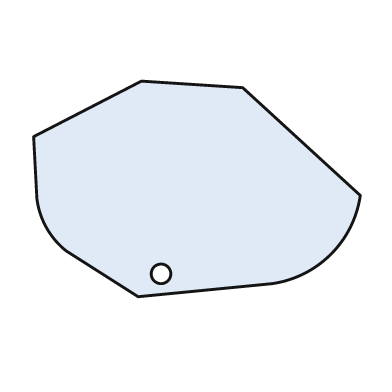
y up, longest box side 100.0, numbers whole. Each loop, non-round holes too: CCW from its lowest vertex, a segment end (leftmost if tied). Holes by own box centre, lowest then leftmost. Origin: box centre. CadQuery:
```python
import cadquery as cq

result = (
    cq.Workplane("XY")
    .moveTo(-18.0, -33.0)
    .lineTo(23.0, -29.0)
    .threePointArc((41.0, -20.0), (50.0, -2.0))
    .lineTo(14.0, 31.0)
    .lineTo(-17.0, 33.0)
    .lineTo(-50.0, 16.0)
    .lineTo(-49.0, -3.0)
    .threePointArc((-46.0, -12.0), (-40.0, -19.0))
    .close()
    .moveTo(-11.0, -26.0)
    .circle(3.0)
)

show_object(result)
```